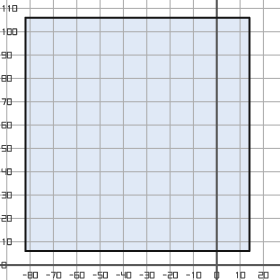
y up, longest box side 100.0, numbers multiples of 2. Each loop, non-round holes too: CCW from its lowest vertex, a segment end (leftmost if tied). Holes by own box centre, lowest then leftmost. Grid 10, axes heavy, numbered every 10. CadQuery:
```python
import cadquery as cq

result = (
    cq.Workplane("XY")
    .moveTo(-82.0, 6.0)
    .lineTo(14.0, 6.0)
    .lineTo(14.0, 106.0)
    .lineTo(-82.0, 106.0)
    .close()
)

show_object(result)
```